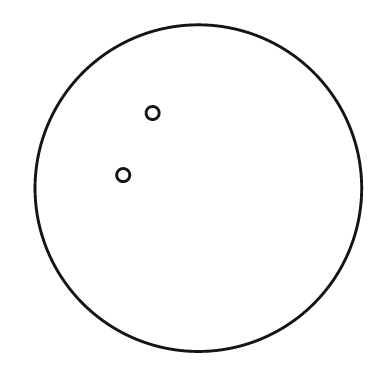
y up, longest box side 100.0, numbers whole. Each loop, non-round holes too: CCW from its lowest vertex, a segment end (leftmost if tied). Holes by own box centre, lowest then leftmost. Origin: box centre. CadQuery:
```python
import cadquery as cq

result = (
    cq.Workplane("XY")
    .moveTo(0.0, 0.0)
    .circle(50.0)
    .moveTo(-23.0, 4.0)
    .circle(2.0)
    .moveTo(-14.0, 23.0)
    .circle(2.0)
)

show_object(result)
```